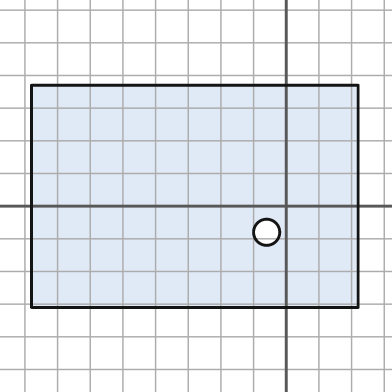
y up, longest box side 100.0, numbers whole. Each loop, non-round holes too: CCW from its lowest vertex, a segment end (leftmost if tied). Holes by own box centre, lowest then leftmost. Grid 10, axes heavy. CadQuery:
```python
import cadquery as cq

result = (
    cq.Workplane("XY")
    .moveTo(-78.0, -31.0)
    .lineTo(22.0, -31.0)
    .lineTo(22.0, 37.0)
    .lineTo(-78.0, 37.0)
    .close()
    .moveTo(-6.0, -8.0)
    .circle(4.0)
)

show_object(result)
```